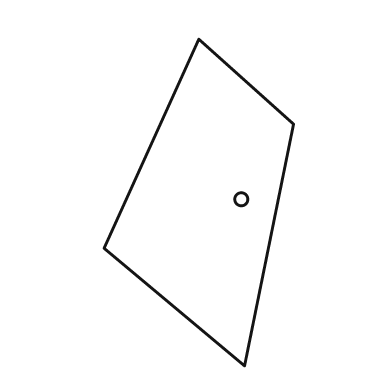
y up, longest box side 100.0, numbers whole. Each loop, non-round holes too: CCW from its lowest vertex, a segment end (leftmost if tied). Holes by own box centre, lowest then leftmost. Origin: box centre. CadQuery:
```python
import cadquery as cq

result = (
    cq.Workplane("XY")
    .moveTo(14.0, -50.0)
    .lineTo(29.0, 24.0)
    .lineTo(0.0, 50.0)
    .lineTo(-29.0, -14.0)
    .close()
    .moveTo(13.0, 1.0)
    .circle(2.0)
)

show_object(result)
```